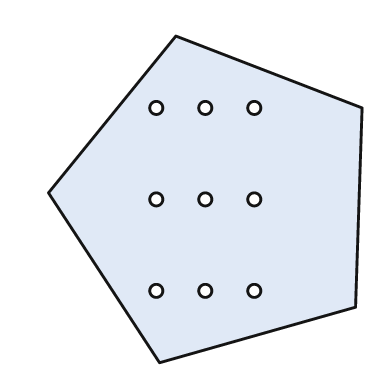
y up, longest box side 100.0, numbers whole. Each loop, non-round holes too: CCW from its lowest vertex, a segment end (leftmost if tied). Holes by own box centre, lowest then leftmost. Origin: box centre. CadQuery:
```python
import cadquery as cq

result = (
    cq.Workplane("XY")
    .moveTo(-14.0, -50.0)
    .lineTo(46.0, -33.0)
    .lineTo(48.0, 28.0)
    .lineTo(-9.0, 50.0)
    .lineTo(-48.0, 2.0)
    .close()
    .moveTo(-15.0, -28.0)
    .circle(2.0)
    .moveTo(0.0, -28.0)
    .circle(2.0)
    .moveTo(15.0, -28.0)
    .circle(2.0)
    .moveTo(-15.0, 0.0)
    .circle(2.0)
    .moveTo(0.0, 0.0)
    .circle(2.0)
    .moveTo(15.0, 0.0)
    .circle(2.0)
    .moveTo(-15.0, 28.0)
    .circle(2.0)
    .moveTo(0.0, 28.0)
    .circle(2.0)
    .moveTo(15.0, 28.0)
    .circle(2.0)
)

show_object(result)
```